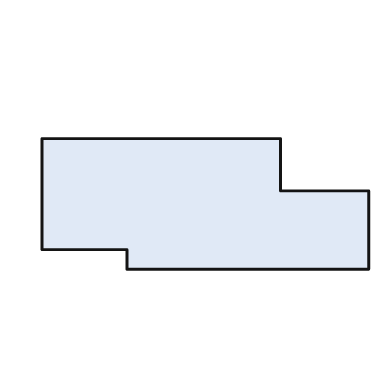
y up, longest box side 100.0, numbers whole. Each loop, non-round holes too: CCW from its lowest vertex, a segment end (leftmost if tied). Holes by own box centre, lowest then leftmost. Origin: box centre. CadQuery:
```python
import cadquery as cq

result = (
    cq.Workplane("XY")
    .moveTo(-24.0, -20.0)
    .lineTo(50.0, -20.0)
    .lineTo(50.0, 4.0)
    .lineTo(23.0, 4.0)
    .lineTo(23.0, 20.0)
    .lineTo(-50.0, 20.0)
    .lineTo(-50.0, -14.0)
    .lineTo(-24.0, -14.0)
    .close()
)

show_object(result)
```